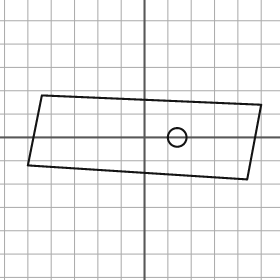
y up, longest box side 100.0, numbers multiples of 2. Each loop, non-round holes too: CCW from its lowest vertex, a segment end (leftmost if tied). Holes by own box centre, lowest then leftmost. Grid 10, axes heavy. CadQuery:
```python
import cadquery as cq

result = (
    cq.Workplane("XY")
    .moveTo(44.0, -18.0)
    .lineTo(50.0, 14.0)
    .lineTo(-44.0, 18.0)
    .lineTo(-50.0, -12.0)
    .close()
    .moveTo(14.0, 0.0)
    .circle(4.0)
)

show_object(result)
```